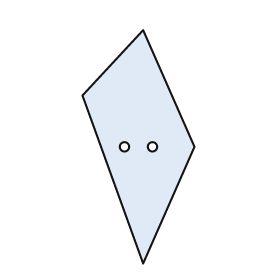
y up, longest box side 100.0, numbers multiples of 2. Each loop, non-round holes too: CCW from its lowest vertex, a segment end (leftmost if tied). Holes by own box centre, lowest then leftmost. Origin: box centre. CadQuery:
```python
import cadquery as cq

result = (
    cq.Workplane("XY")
    .moveTo(2.0, -50.0)
    .lineTo(24.0, 0.0)
    .lineTo(2.0, 50.0)
    .lineTo(-24.0, 22.0)
    .close()
    .moveTo(-6.0, 0.0)
    .circle(2.0)
    .moveTo(6.0, 0.0)
    .circle(2.0)
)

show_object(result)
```